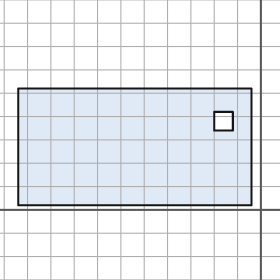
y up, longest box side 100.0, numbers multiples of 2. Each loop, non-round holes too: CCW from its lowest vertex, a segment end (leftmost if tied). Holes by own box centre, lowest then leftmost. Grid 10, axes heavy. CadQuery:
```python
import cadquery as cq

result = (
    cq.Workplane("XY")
    .moveTo(-104.0, 2.0)
    .lineTo(-4.0, 2.0)
    .lineTo(-4.0, 52.0)
    .lineTo(-104.0, 52.0)
    .close()
    .moveTo(-20.0, 34.0)
    .lineTo(-12.0, 34.0)
    .lineTo(-12.0, 42.0)
    .lineTo(-20.0, 42.0)
    .close()
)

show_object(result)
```